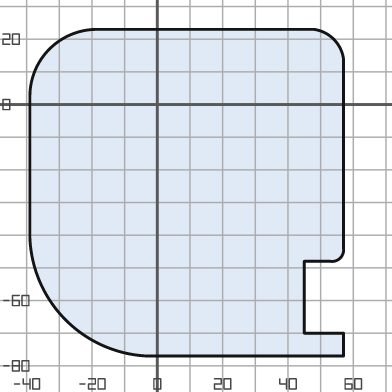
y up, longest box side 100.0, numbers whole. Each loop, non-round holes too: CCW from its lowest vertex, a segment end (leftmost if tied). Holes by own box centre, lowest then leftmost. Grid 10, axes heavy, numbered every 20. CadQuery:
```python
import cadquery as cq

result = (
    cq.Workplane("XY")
    .moveTo(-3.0, -77.0)
    .lineTo(57.0, -77.0)
    .lineTo(57.0, -70.0)
    .lineTo(45.0, -70.0)
    .lineTo(45.0, -48.0)
    .lineTo(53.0, -48.0)
    .threePointArc((56.0, -47.0), (57.0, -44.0))
    .lineTo(57.0, 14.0)
    .threePointArc((54.0, 20.0), (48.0, 23.0))
    .lineTo(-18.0, 23.0)
    .threePointArc((-33.0, 17.0), (-39.0, 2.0))
    .lineTo(-39.0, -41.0)
    .threePointArc((-28.0, -66.0), (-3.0, -77.0))
    .close()
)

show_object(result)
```